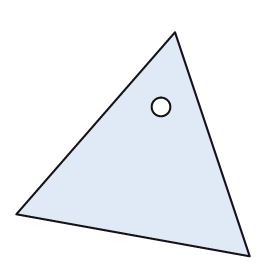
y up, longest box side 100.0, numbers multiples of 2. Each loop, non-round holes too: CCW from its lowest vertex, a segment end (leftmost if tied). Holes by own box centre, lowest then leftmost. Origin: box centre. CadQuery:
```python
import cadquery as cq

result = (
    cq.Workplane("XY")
    .moveTo(50.0, -48.0)
    .lineTo(18.0, 48.0)
    .lineTo(-50.0, -30.0)
    .close()
    .moveTo(12.0, 16.0)
    .circle(4.0)
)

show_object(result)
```